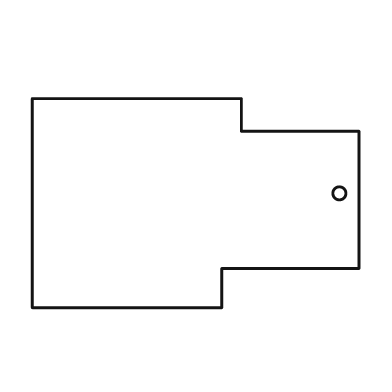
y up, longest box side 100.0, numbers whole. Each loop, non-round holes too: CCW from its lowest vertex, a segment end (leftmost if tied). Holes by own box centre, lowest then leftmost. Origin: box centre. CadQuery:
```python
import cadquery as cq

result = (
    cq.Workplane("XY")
    .moveTo(-50.0, -32.0)
    .lineTo(8.0, -32.0)
    .lineTo(8.0, -20.0)
    .lineTo(50.0, -20.0)
    .lineTo(50.0, 22.0)
    .lineTo(14.0, 22.0)
    .lineTo(14.0, 32.0)
    .lineTo(-50.0, 32.0)
    .close()
    .moveTo(44.0, 3.0)
    .circle(2.0)
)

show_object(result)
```